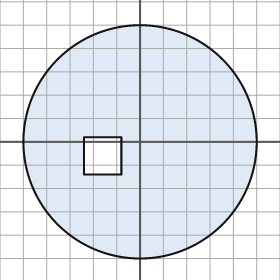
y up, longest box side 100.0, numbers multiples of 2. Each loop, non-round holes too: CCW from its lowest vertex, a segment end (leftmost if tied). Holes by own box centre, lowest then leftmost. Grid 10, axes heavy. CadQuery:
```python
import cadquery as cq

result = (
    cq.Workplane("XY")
    .moveTo(0.0, 0.0)
    .circle(50.0)
    .moveTo(-24.0, -14.0)
    .lineTo(-8.0, -14.0)
    .lineTo(-8.0, 2.0)
    .lineTo(-24.0, 2.0)
    .close()
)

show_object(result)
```